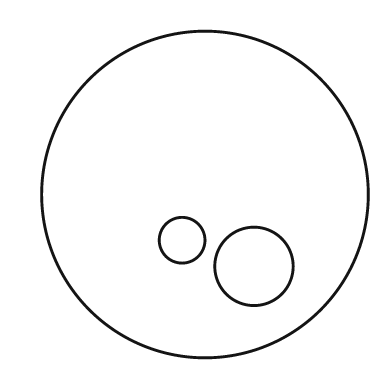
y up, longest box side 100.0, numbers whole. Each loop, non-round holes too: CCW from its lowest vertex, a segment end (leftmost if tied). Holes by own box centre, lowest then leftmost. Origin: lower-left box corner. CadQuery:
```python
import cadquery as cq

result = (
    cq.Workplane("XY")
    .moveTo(50.0, 50.0)
    .circle(50.0)
    .moveTo(65.0, 28.0)
    .circle(12.0)
    .moveTo(43.0, 36.0)
    .circle(7.0)
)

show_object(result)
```